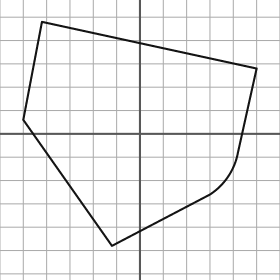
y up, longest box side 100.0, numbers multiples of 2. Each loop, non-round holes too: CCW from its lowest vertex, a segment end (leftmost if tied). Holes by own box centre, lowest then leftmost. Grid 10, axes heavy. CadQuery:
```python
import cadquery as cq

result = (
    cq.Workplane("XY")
    .moveTo(-12.0, -48.0)
    .lineTo(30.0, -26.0)
    .threePointArc((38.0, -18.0), (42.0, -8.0))
    .lineTo(50.0, 28.0)
    .lineTo(-42.0, 48.0)
    .lineTo(-50.0, 6.0)
    .close()
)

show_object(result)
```